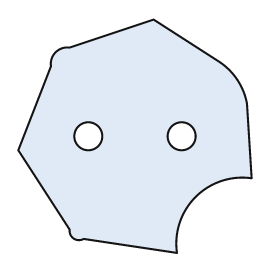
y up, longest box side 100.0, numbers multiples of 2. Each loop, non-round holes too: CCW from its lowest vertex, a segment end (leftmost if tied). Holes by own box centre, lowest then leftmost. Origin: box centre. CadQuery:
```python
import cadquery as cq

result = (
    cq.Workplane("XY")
    .moveTo(18.0, -50.0)
    .threePointArc((26.0, -26.0), (50.0, -18.0))
    .lineTo(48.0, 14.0)
    .threePointArc((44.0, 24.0), (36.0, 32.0))
    .lineTo(8.0, 50.0)
    .lineTo(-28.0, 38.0)
    .threePointArc((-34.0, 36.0), (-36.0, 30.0))
    .lineTo(-50.0, -6.0)
    .lineTo(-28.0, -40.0)
    .threePointArc((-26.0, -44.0), (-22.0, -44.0))
    .close()
    .moveTo(-20.0, 0.0)
    .circle(6.0)
    .moveTo(20.0, 0.0)
    .circle(6.0)
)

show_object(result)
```